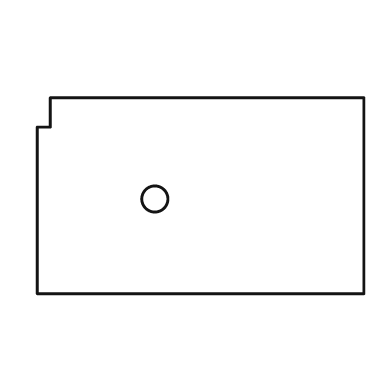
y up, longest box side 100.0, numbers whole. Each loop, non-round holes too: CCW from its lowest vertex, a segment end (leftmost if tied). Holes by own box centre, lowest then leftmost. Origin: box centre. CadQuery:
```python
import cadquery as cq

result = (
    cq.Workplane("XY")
    .moveTo(-50.0, -30.0)
    .lineTo(50.0, -30.0)
    .lineTo(50.0, 30.0)
    .lineTo(-46.0, 30.0)
    .lineTo(-46.0, 21.0)
    .lineTo(-50.0, 21.0)
    .close()
    .moveTo(-14.0, -1.0)
    .circle(4.0)
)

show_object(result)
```